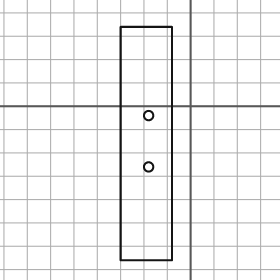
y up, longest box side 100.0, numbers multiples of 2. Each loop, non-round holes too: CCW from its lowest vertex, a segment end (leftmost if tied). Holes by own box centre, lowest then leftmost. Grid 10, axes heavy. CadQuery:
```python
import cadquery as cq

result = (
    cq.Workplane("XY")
    .moveTo(-30.0, -66.0)
    .lineTo(-8.0, -66.0)
    .lineTo(-8.0, 34.0)
    .lineTo(-30.0, 34.0)
    .close()
    .moveTo(-18.0, -26.0)
    .circle(2.0)
    .moveTo(-18.0, -4.0)
    .circle(2.0)
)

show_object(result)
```